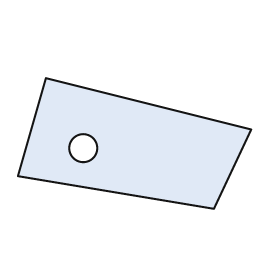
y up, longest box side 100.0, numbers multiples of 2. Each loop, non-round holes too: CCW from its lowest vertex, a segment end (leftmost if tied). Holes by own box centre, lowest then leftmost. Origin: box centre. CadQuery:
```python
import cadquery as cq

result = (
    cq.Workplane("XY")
    .moveTo(34.0, -28.0)
    .lineTo(50.0, 6.0)
    .lineTo(-38.0, 28.0)
    .lineTo(-50.0, -14.0)
    .close()
    .moveTo(-22.0, -2.0)
    .circle(6.0)
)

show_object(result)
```